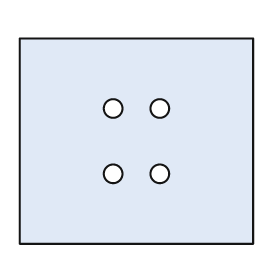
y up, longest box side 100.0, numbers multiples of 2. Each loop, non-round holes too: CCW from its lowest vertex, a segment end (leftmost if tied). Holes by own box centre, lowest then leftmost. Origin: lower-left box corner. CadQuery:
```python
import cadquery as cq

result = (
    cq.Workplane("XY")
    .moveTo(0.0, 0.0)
    .lineTo(100.0, 0.0)
    .lineTo(100.0, 88.0)
    .lineTo(0.0, 88.0)
    .close()
    .moveTo(40.0, 30.0)
    .circle(4.0)
    .moveTo(60.0, 30.0)
    .circle(4.0)
    .moveTo(40.0, 58.0)
    .circle(4.0)
    .moveTo(60.0, 58.0)
    .circle(4.0)
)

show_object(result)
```